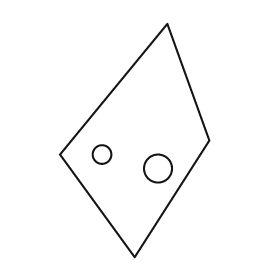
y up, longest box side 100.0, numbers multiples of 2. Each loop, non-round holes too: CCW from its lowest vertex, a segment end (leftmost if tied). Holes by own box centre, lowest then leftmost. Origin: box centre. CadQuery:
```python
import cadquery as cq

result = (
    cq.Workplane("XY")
    .moveTo(0.0, -50.0)
    .lineTo(32.0, 0.0)
    .lineTo(14.0, 50.0)
    .lineTo(-32.0, -6.0)
    .close()
    .moveTo(10.0, -12.0)
    .circle(6.0)
    .moveTo(-14.0, -6.0)
    .circle(4.0)
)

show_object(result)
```